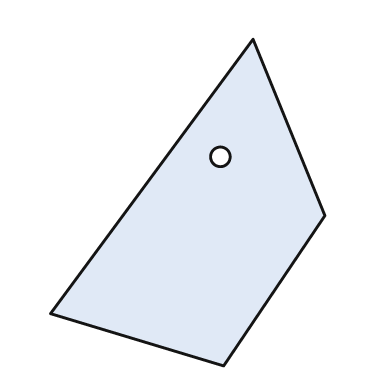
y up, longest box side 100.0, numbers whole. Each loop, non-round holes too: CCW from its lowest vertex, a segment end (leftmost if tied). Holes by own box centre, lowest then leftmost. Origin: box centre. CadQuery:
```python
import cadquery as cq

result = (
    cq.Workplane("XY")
    .moveTo(11.0, -50.0)
    .lineTo(42.0, -4.0)
    .lineTo(20.0, 50.0)
    .lineTo(-42.0, -34.0)
    .close()
    .moveTo(10.0, 14.0)
    .circle(3.0)
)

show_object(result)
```